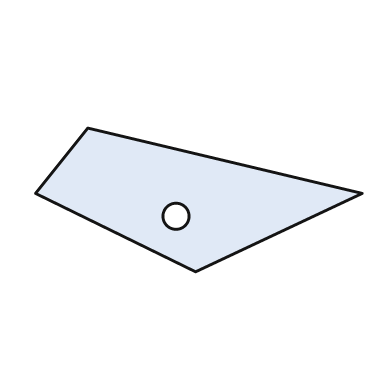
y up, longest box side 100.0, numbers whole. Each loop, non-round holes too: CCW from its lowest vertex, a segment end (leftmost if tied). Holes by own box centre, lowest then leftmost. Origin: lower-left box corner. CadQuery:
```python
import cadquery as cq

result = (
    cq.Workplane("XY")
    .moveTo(49.0, 0.0)
    .lineTo(100.0, 24.0)
    .lineTo(16.0, 44.0)
    .lineTo(0.0, 24.0)
    .close()
    .moveTo(43.0, 17.0)
    .circle(4.0)
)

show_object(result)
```